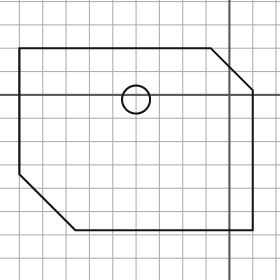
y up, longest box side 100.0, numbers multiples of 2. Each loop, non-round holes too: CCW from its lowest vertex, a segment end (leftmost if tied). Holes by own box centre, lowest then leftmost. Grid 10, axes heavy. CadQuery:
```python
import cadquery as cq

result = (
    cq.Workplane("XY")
    .moveTo(-66.0, -58.0)
    .lineTo(10.0, -58.0)
    .lineTo(10.0, 2.0)
    .lineTo(-8.0, 20.0)
    .lineTo(-90.0, 20.0)
    .lineTo(-90.0, -34.0)
    .close()
    .moveTo(-40.0, -2.0)
    .circle(6.0)
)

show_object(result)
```